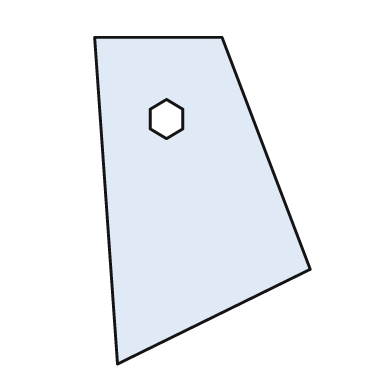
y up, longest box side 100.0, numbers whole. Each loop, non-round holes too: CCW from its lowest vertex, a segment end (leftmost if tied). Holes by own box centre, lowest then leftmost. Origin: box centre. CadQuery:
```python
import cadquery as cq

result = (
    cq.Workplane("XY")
    .moveTo(-26.0, -50.0)
    .lineTo(33.0, -21.0)
    .lineTo(6.0, 50.0)
    .lineTo(-33.0, 50.0)
    .close()
    .moveTo(-11.0, 19.0)
    .lineTo(-6.0, 22.0)
    .lineTo(-6.0, 28.0)
    .lineTo(-11.0, 31.0)
    .lineTo(-16.0, 28.0)
    .lineTo(-16.0, 22.0)
    .close()
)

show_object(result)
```